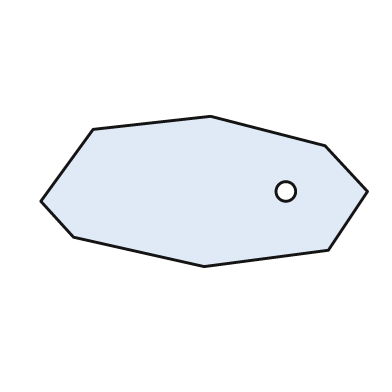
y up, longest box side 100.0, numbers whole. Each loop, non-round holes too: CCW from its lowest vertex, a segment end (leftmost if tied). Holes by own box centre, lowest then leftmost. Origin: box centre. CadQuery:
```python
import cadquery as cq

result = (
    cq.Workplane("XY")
    .moveTo(0.0, -23.0)
    .lineTo(38.0, -18.0)
    .lineTo(50.0, 0.0)
    .lineTo(37.0, 14.0)
    .lineTo(2.0, 23.0)
    .lineTo(-34.0, 19.0)
    .lineTo(-50.0, -3.0)
    .lineTo(-40.0, -14.0)
    .close()
    .moveTo(25.0, 0.0)
    .circle(3.0)
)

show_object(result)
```